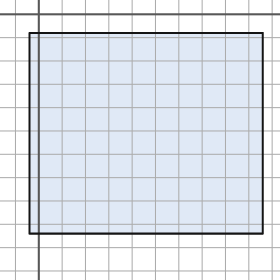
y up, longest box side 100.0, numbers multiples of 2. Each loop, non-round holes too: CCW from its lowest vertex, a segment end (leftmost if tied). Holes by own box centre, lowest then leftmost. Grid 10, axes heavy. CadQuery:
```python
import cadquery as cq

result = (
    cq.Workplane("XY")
    .moveTo(-4.0, -94.0)
    .lineTo(96.0, -94.0)
    .lineTo(96.0, -8.0)
    .lineTo(-4.0, -8.0)
    .close()
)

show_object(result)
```